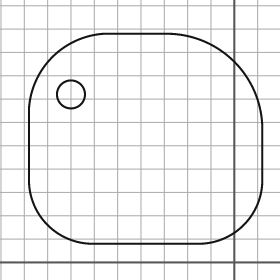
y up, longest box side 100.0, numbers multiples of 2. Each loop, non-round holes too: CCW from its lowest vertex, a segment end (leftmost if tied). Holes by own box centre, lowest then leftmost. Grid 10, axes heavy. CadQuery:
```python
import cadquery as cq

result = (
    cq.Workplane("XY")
    .moveTo(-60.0, 8.0)
    .lineTo(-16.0, 8.0)
    .threePointArc((4.0, 16.0), (12.0, 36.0))
    .lineTo(12.0, 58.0)
    .threePointArc((0.0, 86.0), (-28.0, 98.0))
    .lineTo(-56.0, 98.0)
    .threePointArc((-78.0, 88.0), (-88.0, 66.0))
    .lineTo(-88.0, 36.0)
    .threePointArc((-80.0, 16.0), (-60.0, 8.0))
    .close()
    .moveTo(-70.0, 72.0)
    .circle(6.0)
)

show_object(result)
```